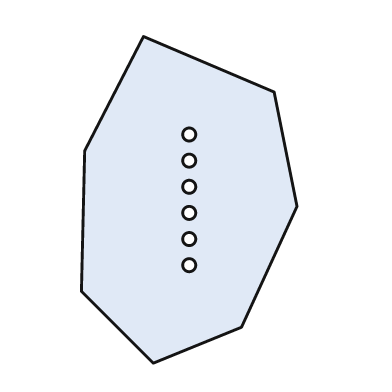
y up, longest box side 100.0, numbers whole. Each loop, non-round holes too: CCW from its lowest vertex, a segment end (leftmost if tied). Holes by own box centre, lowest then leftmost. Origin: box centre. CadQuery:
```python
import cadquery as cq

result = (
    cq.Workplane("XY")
    .moveTo(-11.0, -50.0)
    .lineTo(16.0, -39.0)
    .lineTo(33.0, -2.0)
    .lineTo(26.0, 33.0)
    .lineTo(-14.0, 50.0)
    .lineTo(-32.0, 15.0)
    .lineTo(-33.0, -28.0)
    .close()
    .moveTo(0.0, -20.0)
    .circle(2.0)
    .moveTo(0.0, -12.0)
    .circle(2.0)
    .moveTo(0.0, -4.0)
    .circle(2.0)
    .moveTo(0.0, 4.0)
    .circle(2.0)
    .moveTo(0.0, 12.0)
    .circle(2.0)
    .moveTo(0.0, 20.0)
    .circle(2.0)
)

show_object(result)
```